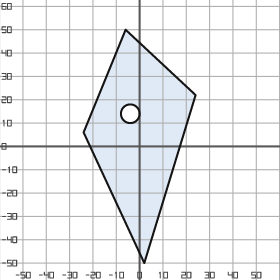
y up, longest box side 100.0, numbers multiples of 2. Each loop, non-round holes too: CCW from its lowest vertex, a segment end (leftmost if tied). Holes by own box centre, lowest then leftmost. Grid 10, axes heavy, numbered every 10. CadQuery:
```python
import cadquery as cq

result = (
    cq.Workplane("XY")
    .moveTo(2.0, -50.0)
    .lineTo(24.0, 22.0)
    .lineTo(-6.0, 50.0)
    .lineTo(-24.0, 6.0)
    .close()
    .moveTo(-4.0, 14.0)
    .circle(4.0)
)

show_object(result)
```